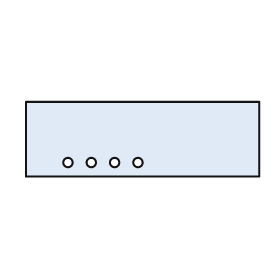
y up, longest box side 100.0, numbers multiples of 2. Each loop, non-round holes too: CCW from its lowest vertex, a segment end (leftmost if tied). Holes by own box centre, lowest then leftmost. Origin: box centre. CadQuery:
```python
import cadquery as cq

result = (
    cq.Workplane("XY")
    .moveTo(-50.0, -16.0)
    .lineTo(50.0, -16.0)
    .lineTo(50.0, 16.0)
    .lineTo(-50.0, 16.0)
    .close()
    .moveTo(-32.0, -10.0)
    .circle(2.0)
    .moveTo(-22.0, -10.0)
    .circle(2.0)
    .moveTo(-12.0, -10.0)
    .circle(2.0)
    .moveTo(-2.0, -10.0)
    .circle(2.0)
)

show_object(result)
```